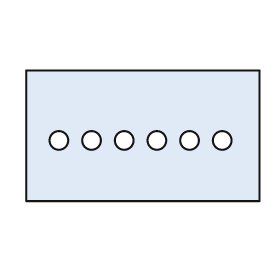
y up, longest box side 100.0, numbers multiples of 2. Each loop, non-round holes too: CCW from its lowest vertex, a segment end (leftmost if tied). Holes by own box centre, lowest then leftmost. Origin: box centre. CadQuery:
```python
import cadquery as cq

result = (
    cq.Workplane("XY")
    .moveTo(-50.0, -28.0)
    .lineTo(50.0, -28.0)
    .lineTo(50.0, 28.0)
    .lineTo(-50.0, 28.0)
    .close()
    .moveTo(-36.0, -2.0)
    .circle(4.0)
    .moveTo(-22.0, -2.0)
    .circle(4.0)
    .moveTo(-8.0, -2.0)
    .circle(4.0)
    .moveTo(6.0, -2.0)
    .circle(4.0)
    .moveTo(20.0, -2.0)
    .circle(4.0)
    .moveTo(34.0, -2.0)
    .circle(4.0)
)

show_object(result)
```